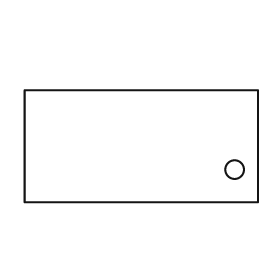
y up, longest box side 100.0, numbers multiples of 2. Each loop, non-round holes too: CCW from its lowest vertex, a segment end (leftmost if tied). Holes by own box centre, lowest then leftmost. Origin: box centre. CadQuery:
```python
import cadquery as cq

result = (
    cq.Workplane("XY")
    .moveTo(-50.0, -24.0)
    .lineTo(50.0, -24.0)
    .lineTo(50.0, 24.0)
    .lineTo(-50.0, 24.0)
    .close()
    .moveTo(40.0, -10.0)
    .circle(4.0)
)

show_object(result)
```